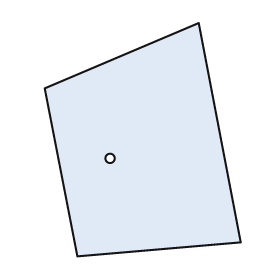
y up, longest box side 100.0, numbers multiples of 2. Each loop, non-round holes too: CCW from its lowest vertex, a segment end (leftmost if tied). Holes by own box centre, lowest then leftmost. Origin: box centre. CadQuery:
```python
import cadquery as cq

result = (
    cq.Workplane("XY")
    .moveTo(-28.0, -50.0)
    .lineTo(42.0, -44.0)
    .lineTo(24.0, 50.0)
    .lineTo(-42.0, 22.0)
    .close()
    .moveTo(-14.0, -8.0)
    .circle(2.0)
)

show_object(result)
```